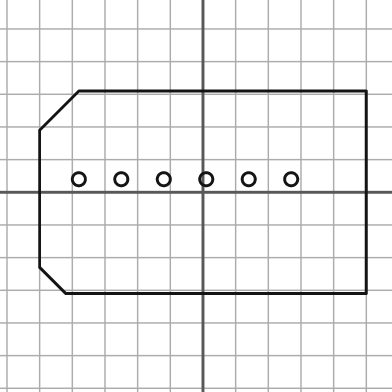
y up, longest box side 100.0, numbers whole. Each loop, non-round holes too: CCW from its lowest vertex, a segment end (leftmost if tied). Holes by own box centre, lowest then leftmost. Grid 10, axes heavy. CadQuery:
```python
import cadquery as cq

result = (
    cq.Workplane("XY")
    .moveTo(-42.0, -31.0)
    .lineTo(50.0, -31.0)
    .lineTo(50.0, 31.0)
    .lineTo(-38.0, 31.0)
    .lineTo(-50.0, 19.0)
    .lineTo(-50.0, -23.0)
    .close()
    .moveTo(-38.0, 4.0)
    .circle(2.0)
    .moveTo(-25.0, 4.0)
    .circle(2.0)
    .moveTo(-12.0, 4.0)
    .circle(2.0)
    .moveTo(1.0, 4.0)
    .circle(2.0)
    .moveTo(14.0, 4.0)
    .circle(2.0)
    .moveTo(27.0, 4.0)
    .circle(2.0)
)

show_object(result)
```